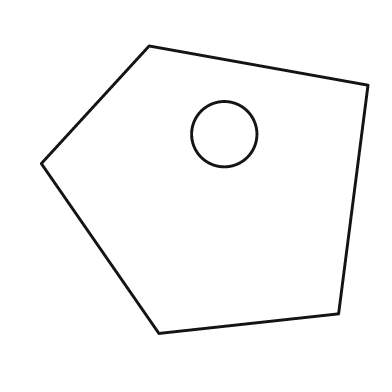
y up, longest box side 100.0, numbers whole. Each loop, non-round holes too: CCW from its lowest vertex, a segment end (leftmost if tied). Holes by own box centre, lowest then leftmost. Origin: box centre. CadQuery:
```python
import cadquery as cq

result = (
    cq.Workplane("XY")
    .moveTo(-14.0, -44.0)
    .lineTo(41.0, -38.0)
    .lineTo(50.0, 32.0)
    .lineTo(-17.0, 44.0)
    .lineTo(-50.0, 8.0)
    .close()
    .moveTo(6.0, 17.0)
    .circle(10.0)
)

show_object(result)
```